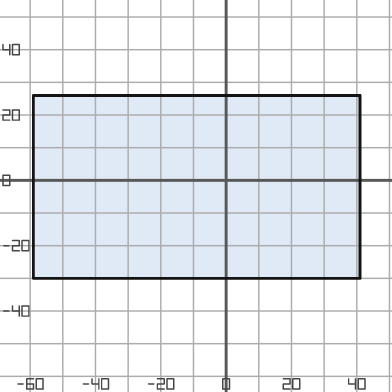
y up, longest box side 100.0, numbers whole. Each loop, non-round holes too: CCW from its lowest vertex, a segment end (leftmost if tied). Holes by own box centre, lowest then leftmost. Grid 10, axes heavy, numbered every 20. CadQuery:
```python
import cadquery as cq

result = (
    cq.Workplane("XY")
    .moveTo(-59.0, -30.0)
    .lineTo(41.0, -30.0)
    .lineTo(41.0, 26.0)
    .lineTo(-59.0, 26.0)
    .close()
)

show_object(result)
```